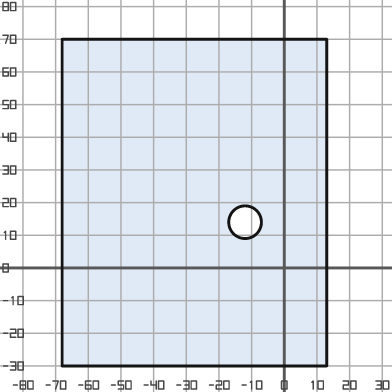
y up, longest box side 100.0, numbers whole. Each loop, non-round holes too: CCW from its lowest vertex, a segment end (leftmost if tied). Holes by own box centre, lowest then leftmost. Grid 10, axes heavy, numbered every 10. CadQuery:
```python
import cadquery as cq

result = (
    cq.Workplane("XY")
    .moveTo(-68.0, -30.0)
    .lineTo(13.0, -30.0)
    .lineTo(13.0, 70.0)
    .lineTo(-68.0, 70.0)
    .close()
    .moveTo(-12.0, 14.0)
    .circle(5.0)
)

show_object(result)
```